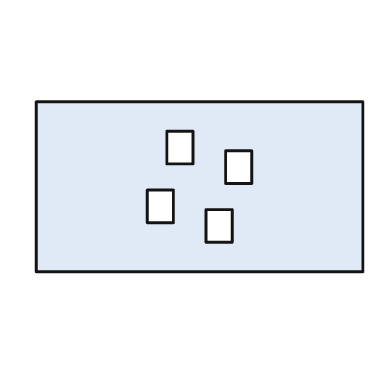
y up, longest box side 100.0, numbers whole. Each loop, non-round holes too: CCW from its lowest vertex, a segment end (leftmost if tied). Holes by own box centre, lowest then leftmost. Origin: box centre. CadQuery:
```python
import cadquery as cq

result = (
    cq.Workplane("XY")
    .moveTo(-50.0, -26.0)
    .lineTo(50.0, -26.0)
    .lineTo(50.0, 26.0)
    .lineTo(-50.0, 26.0)
    .close()
    .moveTo(2.0, -17.0)
    .lineTo(10.0, -17.0)
    .lineTo(10.0, -7.0)
    .lineTo(2.0, -7.0)
    .close()
    .moveTo(-16.0, -11.0)
    .lineTo(-8.0, -11.0)
    .lineTo(-8.0, -1.0)
    .lineTo(-16.0, -1.0)
    .close()
    .moveTo(8.0, 1.0)
    .lineTo(16.0, 1.0)
    .lineTo(16.0, 11.0)
    .lineTo(8.0, 11.0)
    .close()
    .moveTo(-10.0, 7.0)
    .lineTo(-2.0, 7.0)
    .lineTo(-2.0, 17.0)
    .lineTo(-10.0, 17.0)
    .close()
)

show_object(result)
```